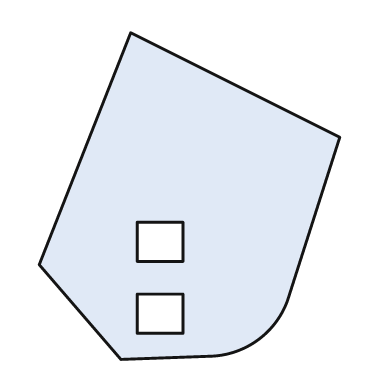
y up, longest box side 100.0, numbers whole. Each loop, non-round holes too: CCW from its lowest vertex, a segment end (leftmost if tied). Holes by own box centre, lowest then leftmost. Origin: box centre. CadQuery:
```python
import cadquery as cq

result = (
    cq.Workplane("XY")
    .moveTo(-21.0, -50.0)
    .lineTo(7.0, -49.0)
    .threePointArc((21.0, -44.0), (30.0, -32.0))
    .lineTo(46.0, 18.0)
    .lineTo(-18.0, 50.0)
    .lineTo(-46.0, -21.0)
    .close()
    .moveTo(-16.0, -42.0)
    .lineTo(-2.0, -42.0)
    .lineTo(-2.0, -30.0)
    .lineTo(-16.0, -30.0)
    .close()
    .moveTo(-16.0, -20.0)
    .lineTo(-2.0, -20.0)
    .lineTo(-2.0, -8.0)
    .lineTo(-16.0, -8.0)
    .close()
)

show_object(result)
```